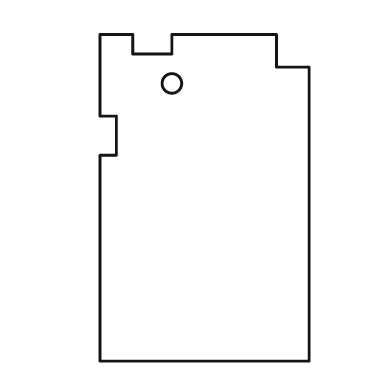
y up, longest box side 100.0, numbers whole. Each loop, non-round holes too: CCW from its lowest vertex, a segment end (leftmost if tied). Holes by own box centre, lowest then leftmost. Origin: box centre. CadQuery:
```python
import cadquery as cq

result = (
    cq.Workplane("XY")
    .moveTo(-32.0, -50.0)
    .lineTo(32.0, -50.0)
    .lineTo(32.0, 40.0)
    .lineTo(22.0, 40.0)
    .lineTo(22.0, 50.0)
    .lineTo(-10.0, 50.0)
    .lineTo(-10.0, 44.0)
    .lineTo(-22.0, 44.0)
    .lineTo(-22.0, 50.0)
    .lineTo(-32.0, 50.0)
    .lineTo(-32.0, 25.0)
    .lineTo(-27.0, 25.0)
    .lineTo(-27.0, 13.0)
    .lineTo(-32.0, 13.0)
    .close()
    .moveTo(-10.0, 35.0)
    .circle(3.0)
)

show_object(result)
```